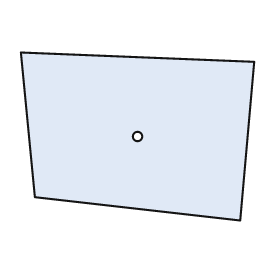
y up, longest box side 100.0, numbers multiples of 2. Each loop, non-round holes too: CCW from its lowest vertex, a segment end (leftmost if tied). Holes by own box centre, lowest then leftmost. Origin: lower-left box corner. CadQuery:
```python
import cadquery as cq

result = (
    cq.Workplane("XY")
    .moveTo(94.0, 0.0)
    .lineTo(100.0, 68.0)
    .lineTo(0.0, 72.0)
    .lineTo(6.0, 10.0)
    .close()
    .moveTo(50.0, 36.0)
    .circle(2.0)
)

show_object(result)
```